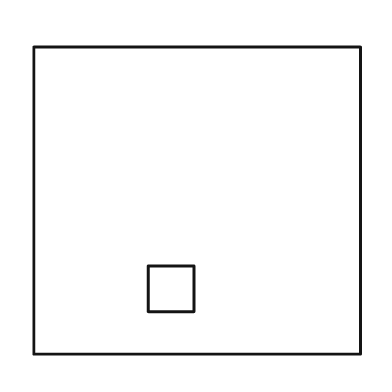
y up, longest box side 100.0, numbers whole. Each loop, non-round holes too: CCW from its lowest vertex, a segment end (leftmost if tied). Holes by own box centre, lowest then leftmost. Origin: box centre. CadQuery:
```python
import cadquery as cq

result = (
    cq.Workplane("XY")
    .moveTo(-50.0, -47.0)
    .lineTo(50.0, -47.0)
    .lineTo(50.0, 47.0)
    .lineTo(-50.0, 47.0)
    .close()
    .moveTo(-15.0, -34.0)
    .lineTo(-1.0, -34.0)
    .lineTo(-1.0, -20.0)
    .lineTo(-15.0, -20.0)
    .close()
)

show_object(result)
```